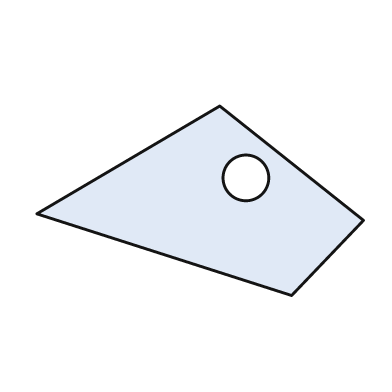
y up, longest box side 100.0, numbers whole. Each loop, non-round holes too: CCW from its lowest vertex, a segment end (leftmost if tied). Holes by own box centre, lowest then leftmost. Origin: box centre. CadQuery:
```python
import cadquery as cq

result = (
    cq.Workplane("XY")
    .moveTo(28.0, -29.0)
    .lineTo(50.0, -6.0)
    .lineTo(6.0, 29.0)
    .lineTo(-50.0, -4.0)
    .close()
    .moveTo(14.0, 7.0)
    .circle(7.0)
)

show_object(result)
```